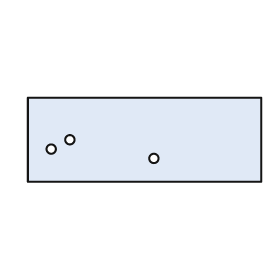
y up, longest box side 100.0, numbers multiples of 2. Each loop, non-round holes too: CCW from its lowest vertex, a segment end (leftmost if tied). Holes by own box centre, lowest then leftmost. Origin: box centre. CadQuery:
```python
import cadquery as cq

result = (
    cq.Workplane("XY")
    .moveTo(-50.0, -18.0)
    .lineTo(50.0, -18.0)
    .lineTo(50.0, 18.0)
    .lineTo(-50.0, 18.0)
    .close()
    .moveTo(4.0, -8.0)
    .circle(2.0)
    .moveTo(-40.0, -4.0)
    .circle(2.0)
    .moveTo(-32.0, 0.0)
    .circle(2.0)
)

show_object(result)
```